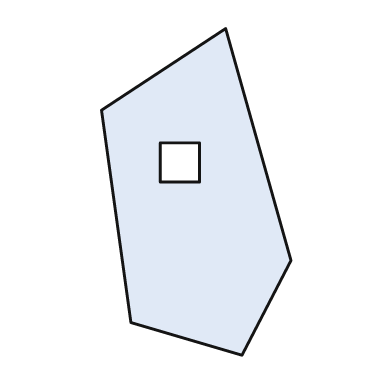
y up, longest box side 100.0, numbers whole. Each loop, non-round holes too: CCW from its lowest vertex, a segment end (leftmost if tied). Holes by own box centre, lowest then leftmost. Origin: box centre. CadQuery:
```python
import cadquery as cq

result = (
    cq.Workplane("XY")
    .moveTo(14.0, -50.0)
    .lineTo(29.0, -21.0)
    .lineTo(9.0, 50.0)
    .lineTo(-29.0, 25.0)
    .lineTo(-20.0, -40.0)
    .close()
    .moveTo(-11.0, 3.0)
    .lineTo(1.0, 3.0)
    .lineTo(1.0, 15.0)
    .lineTo(-11.0, 15.0)
    .close()
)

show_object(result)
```